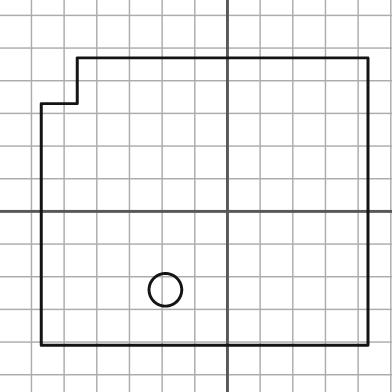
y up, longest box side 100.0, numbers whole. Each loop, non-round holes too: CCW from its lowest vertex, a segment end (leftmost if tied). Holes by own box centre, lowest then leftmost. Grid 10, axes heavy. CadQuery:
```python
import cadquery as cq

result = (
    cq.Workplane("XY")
    .moveTo(-57.0, -41.0)
    .lineTo(43.0, -41.0)
    .lineTo(43.0, 47.0)
    .lineTo(-46.0, 47.0)
    .lineTo(-46.0, 33.0)
    .lineTo(-57.0, 33.0)
    .close()
    .moveTo(-19.0, -24.0)
    .circle(5.0)
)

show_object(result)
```